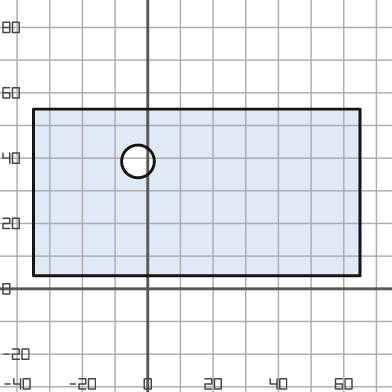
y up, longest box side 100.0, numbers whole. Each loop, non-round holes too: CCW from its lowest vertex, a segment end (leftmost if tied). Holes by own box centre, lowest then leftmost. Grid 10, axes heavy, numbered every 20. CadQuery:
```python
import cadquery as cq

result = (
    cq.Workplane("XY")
    .moveTo(-35.0, 4.0)
    .lineTo(65.0, 4.0)
    .lineTo(65.0, 55.0)
    .lineTo(-35.0, 55.0)
    .close()
    .moveTo(-3.0, 39.0)
    .circle(5.0)
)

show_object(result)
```